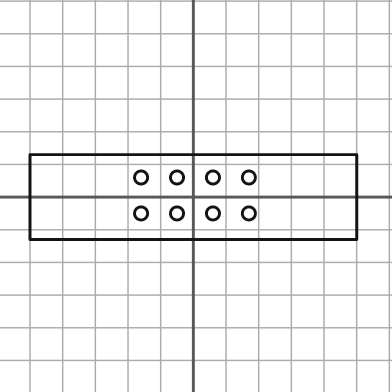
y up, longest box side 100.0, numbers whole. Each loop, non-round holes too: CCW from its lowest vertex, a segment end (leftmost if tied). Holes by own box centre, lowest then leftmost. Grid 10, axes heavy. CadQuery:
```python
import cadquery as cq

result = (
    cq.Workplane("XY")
    .moveTo(-50.0, -13.0)
    .lineTo(50.0, -13.0)
    .lineTo(50.0, 13.0)
    .lineTo(-50.0, 13.0)
    .close()
    .moveTo(-16.0, -5.0)
    .circle(2.0)
    .moveTo(-5.0, -5.0)
    .circle(2.0)
    .moveTo(6.0, -5.0)
    .circle(2.0)
    .moveTo(17.0, -5.0)
    .circle(2.0)
    .moveTo(-16.0, 6.0)
    .circle(2.0)
    .moveTo(-5.0, 6.0)
    .circle(2.0)
    .moveTo(6.0, 6.0)
    .circle(2.0)
    .moveTo(17.0, 6.0)
    .circle(2.0)
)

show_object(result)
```